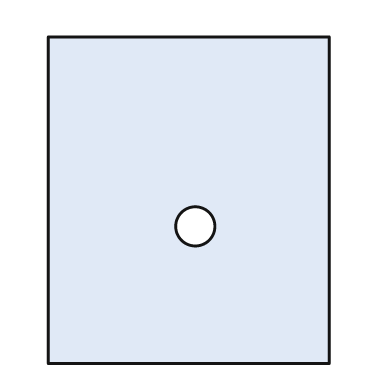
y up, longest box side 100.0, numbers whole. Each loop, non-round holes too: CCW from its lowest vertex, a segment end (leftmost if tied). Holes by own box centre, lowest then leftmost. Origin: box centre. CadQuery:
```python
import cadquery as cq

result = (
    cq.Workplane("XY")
    .moveTo(-43.0, -50.0)
    .lineTo(43.0, -50.0)
    .lineTo(43.0, 50.0)
    .lineTo(-43.0, 50.0)
    .close()
    .moveTo(2.0, -8.0)
    .circle(6.0)
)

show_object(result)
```